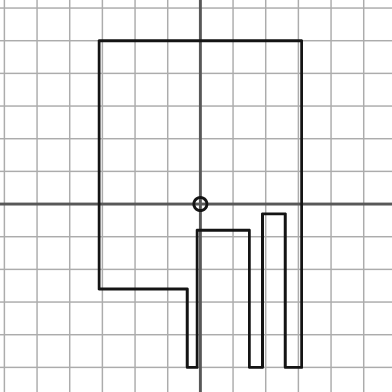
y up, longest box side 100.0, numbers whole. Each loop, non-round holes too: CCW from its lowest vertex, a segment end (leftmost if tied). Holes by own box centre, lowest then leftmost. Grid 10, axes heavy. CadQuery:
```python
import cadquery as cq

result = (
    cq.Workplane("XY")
    .moveTo(-4.0, -50.0)
    .lineTo(-1.0, -50.0)
    .lineTo(-1.0, -8.0)
    .lineTo(15.0, -8.0)
    .lineTo(15.0, -50.0)
    .lineTo(19.0, -50.0)
    .lineTo(19.0, -3.0)
    .lineTo(26.0, -3.0)
    .lineTo(26.0, -50.0)
    .lineTo(31.0, -50.0)
    .lineTo(31.0, 50.0)
    .lineTo(-31.0, 50.0)
    .lineTo(-31.0, -26.0)
    .lineTo(-4.0, -26.0)
    .close()
    .moveTo(0.0, 0.0)
    .circle(2.0)
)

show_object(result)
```